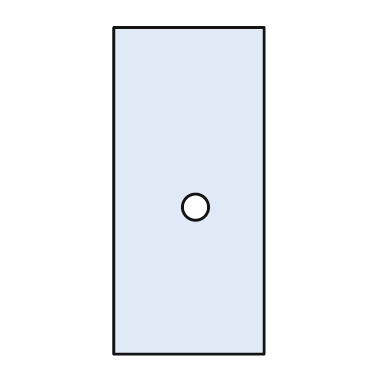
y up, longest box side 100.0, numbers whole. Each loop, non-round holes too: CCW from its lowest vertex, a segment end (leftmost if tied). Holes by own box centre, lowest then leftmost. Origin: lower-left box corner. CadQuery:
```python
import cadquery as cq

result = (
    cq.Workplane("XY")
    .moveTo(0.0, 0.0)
    .lineTo(46.0, 0.0)
    .lineTo(46.0, 100.0)
    .lineTo(0.0, 100.0)
    .close()
    .moveTo(25.0, 45.0)
    .circle(4.0)
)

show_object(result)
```